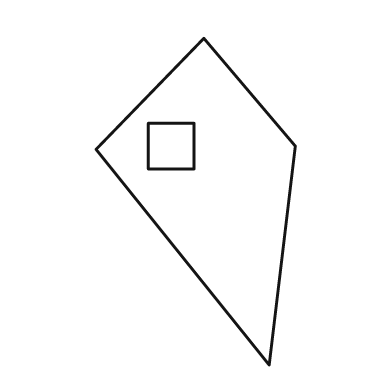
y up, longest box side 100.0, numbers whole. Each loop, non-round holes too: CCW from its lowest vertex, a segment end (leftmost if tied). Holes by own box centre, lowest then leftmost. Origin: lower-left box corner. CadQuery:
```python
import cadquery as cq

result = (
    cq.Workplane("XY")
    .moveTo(53.0, 0.0)
    .lineTo(61.0, 67.0)
    .lineTo(33.0, 100.0)
    .lineTo(0.0, 66.0)
    .close()
    .moveTo(16.0, 60.0)
    .lineTo(30.0, 60.0)
    .lineTo(30.0, 74.0)
    .lineTo(16.0, 74.0)
    .close()
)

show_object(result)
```